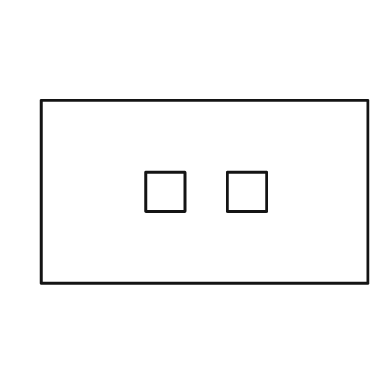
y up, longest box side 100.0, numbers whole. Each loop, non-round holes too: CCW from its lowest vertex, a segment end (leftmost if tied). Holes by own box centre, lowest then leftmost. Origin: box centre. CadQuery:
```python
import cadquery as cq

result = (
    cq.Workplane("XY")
    .moveTo(-50.0, -28.0)
    .lineTo(50.0, -28.0)
    .lineTo(50.0, 28.0)
    .lineTo(-50.0, 28.0)
    .close()
    .moveTo(-18.0, -6.0)
    .lineTo(-6.0, -6.0)
    .lineTo(-6.0, 6.0)
    .lineTo(-18.0, 6.0)
    .close()
    .moveTo(7.0, -6.0)
    .lineTo(19.0, -6.0)
    .lineTo(19.0, 6.0)
    .lineTo(7.0, 6.0)
    .close()
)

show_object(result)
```